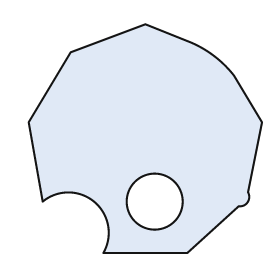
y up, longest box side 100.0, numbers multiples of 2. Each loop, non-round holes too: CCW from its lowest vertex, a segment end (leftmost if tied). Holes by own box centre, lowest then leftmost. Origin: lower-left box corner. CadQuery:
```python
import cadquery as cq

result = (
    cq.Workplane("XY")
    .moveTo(32.0, 0.0)
    .lineTo(68.0, 0.0)
    .lineTo(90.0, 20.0)
    .threePointArc((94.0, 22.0), (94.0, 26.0))
    .lineTo(100.0, 56.0)
    .lineTo(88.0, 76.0)
    .threePointArc((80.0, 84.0), (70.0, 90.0))
    .lineTo(50.0, 98.0)
    .lineTo(18.0, 86.0)
    .lineTo(0.0, 56.0)
    .lineTo(6.0, 22.0)
    .threePointArc((28.0, 22.0), (32.0, 0.0))
    .close()
    .moveTo(54.0, 22.0)
    .circle(12.0)
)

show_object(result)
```